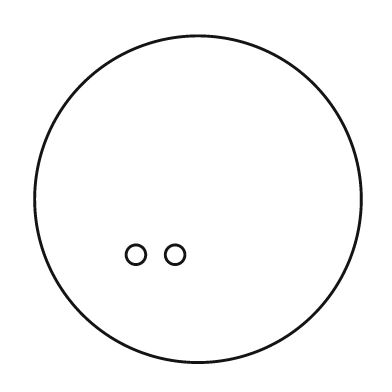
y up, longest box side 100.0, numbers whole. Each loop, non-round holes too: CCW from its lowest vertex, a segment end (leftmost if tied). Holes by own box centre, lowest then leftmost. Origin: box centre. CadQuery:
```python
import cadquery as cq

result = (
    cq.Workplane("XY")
    .moveTo(0.0, 0.0)
    .circle(50.0)
    .moveTo(-19.0, -17.0)
    .circle(3.0)
    .moveTo(-7.0, -17.0)
    .circle(3.0)
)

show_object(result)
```